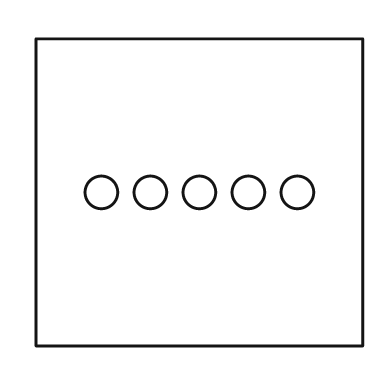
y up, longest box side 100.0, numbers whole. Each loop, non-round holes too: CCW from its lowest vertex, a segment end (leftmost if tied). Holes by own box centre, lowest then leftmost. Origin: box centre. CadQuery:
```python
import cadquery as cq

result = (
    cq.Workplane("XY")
    .moveTo(-50.0, -47.0)
    .lineTo(50.0, -47.0)
    .lineTo(50.0, 47.0)
    .lineTo(-50.0, 47.0)
    .close()
    .moveTo(-30.0, 0.0)
    .circle(5.0)
    .moveTo(-15.0, 0.0)
    .circle(5.0)
    .moveTo(0.0, 0.0)
    .circle(5.0)
    .moveTo(15.0, 0.0)
    .circle(5.0)
    .moveTo(30.0, 0.0)
    .circle(5.0)
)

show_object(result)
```